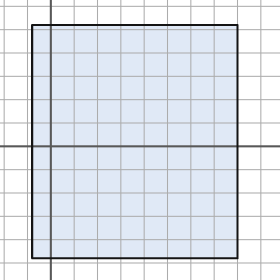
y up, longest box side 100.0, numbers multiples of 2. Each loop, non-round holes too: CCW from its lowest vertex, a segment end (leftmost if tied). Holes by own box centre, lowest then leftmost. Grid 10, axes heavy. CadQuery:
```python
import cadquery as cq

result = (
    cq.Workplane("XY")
    .moveTo(-8.0, -48.0)
    .lineTo(80.0, -48.0)
    .lineTo(80.0, 52.0)
    .lineTo(-8.0, 52.0)
    .close()
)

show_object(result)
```